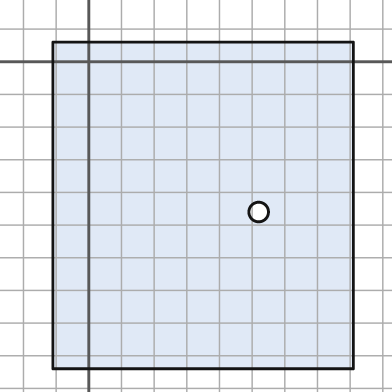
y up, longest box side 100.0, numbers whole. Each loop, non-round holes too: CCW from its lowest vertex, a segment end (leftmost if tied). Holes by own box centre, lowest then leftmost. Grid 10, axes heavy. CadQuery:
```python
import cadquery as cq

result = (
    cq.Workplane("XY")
    .moveTo(-11.0, -94.0)
    .lineTo(81.0, -94.0)
    .lineTo(81.0, 6.0)
    .lineTo(-11.0, 6.0)
    .close()
    .moveTo(52.0, -46.0)
    .circle(3.0)
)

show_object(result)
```